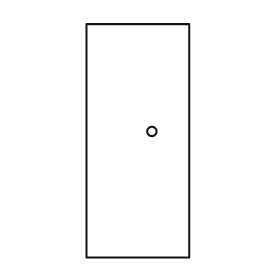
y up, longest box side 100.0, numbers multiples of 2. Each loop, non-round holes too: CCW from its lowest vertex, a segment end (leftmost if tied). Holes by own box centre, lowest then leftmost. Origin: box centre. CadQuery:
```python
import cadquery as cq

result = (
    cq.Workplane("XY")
    .moveTo(-22.0, -50.0)
    .lineTo(22.0, -50.0)
    .lineTo(22.0, 50.0)
    .lineTo(-22.0, 50.0)
    .close()
    .moveTo(6.0, 4.0)
    .circle(2.0)
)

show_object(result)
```